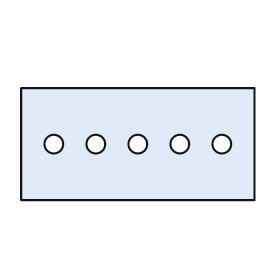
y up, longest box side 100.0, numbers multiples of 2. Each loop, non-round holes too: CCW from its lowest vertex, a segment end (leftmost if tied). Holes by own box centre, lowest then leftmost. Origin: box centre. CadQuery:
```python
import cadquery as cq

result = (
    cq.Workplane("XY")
    .moveTo(-50.0, -24.0)
    .lineTo(50.0, -24.0)
    .lineTo(50.0, 24.0)
    .lineTo(-50.0, 24.0)
    .close()
    .moveTo(-36.0, 0.0)
    .circle(4.0)
    .moveTo(-18.0, 0.0)
    .circle(4.0)
    .moveTo(0.0, 0.0)
    .circle(4.0)
    .moveTo(18.0, 0.0)
    .circle(4.0)
    .moveTo(36.0, 0.0)
    .circle(4.0)
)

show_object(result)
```